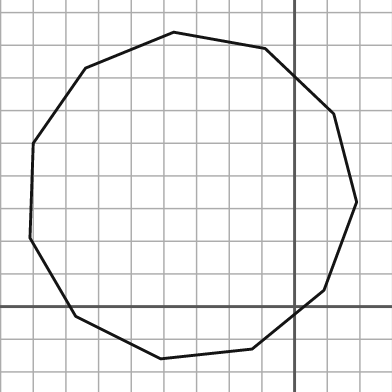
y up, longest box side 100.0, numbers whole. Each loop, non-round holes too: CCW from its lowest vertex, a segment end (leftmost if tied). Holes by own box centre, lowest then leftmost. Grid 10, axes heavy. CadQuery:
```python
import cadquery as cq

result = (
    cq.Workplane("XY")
    .moveTo(-41.0, -16.0)
    .lineTo(-13.0, -13.0)
    .lineTo(9.0, 5.0)
    .lineTo(19.0, 32.0)
    .lineTo(12.0, 59.0)
    .lineTo(-9.0, 79.0)
    .lineTo(-37.0, 84.0)
    .lineTo(-64.0, 73.0)
    .lineTo(-80.0, 50.0)
    .lineTo(-81.0, 21.0)
    .lineTo(-67.0, -3.0)
    .close()
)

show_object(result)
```